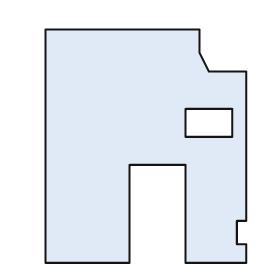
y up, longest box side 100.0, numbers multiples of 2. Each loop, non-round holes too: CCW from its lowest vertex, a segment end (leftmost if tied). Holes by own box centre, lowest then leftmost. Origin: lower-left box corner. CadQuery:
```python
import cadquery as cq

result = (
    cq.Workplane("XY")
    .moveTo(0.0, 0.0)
    .lineTo(36.0, 0.0)
    .lineTo(36.0, 42.0)
    .lineTo(60.0, 42.0)
    .lineTo(60.0, 0.0)
    .lineTo(86.0, 0.0)
    .lineTo(86.0, 8.0)
    .lineTo(82.0, 8.0)
    .lineTo(82.0, 18.0)
    .lineTo(86.0, 18.0)
    .lineTo(86.0, 82.0)
    .lineTo(70.0, 82.0)
    .lineTo(66.0, 90.0)
    .lineTo(66.0, 100.0)
    .lineTo(0.0, 100.0)
    .close()
    .moveTo(60.0, 54.0)
    .lineTo(80.0, 54.0)
    .lineTo(80.0, 66.0)
    .lineTo(60.0, 66.0)
    .close()
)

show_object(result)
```